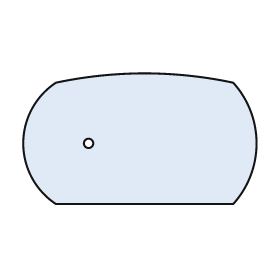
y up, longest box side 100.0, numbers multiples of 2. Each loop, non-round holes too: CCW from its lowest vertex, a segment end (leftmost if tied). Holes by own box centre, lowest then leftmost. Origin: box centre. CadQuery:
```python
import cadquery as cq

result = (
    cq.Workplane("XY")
    .moveTo(-36.0, -28.0)
    .lineTo(40.0, -28.0)
    .threePointArc((50.0, -2.0), (40.0, 24.0))
    .threePointArc((2.0, 28.0), (-36.0, 24.0))
    .threePointArc((-50.0, -2.0), (-36.0, -28.0))
    .close()
    .moveTo(-22.0, -2.0)
    .circle(2.0)
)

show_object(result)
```